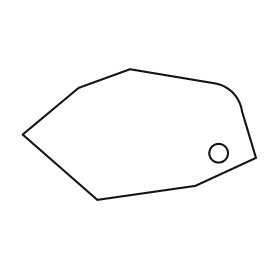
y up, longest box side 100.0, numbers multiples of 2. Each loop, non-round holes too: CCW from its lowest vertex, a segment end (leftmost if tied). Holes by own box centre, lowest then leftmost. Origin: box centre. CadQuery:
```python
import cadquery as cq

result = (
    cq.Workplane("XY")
    .moveTo(-18.0, -28.0)
    .lineTo(24.0, -22.0)
    .lineTo(50.0, -10.0)
    .lineTo(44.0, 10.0)
    .threePointArc((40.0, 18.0), (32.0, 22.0))
    .lineTo(-4.0, 28.0)
    .lineTo(-26.0, 20.0)
    .lineTo(-50.0, 0.0)
    .close()
    .moveTo(34.0, -8.0)
    .circle(4.0)
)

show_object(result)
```